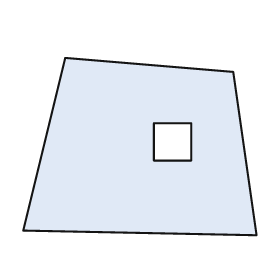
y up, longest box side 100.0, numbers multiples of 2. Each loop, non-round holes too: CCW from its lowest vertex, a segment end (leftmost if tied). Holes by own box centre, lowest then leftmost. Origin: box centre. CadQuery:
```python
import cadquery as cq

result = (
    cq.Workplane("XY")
    .moveTo(50.0, -38.0)
    .lineTo(40.0, 32.0)
    .lineTo(-32.0, 38.0)
    .lineTo(-50.0, -36.0)
    .close()
    .moveTo(6.0, -6.0)
    .lineTo(22.0, -6.0)
    .lineTo(22.0, 10.0)
    .lineTo(6.0, 10.0)
    .close()
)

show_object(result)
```